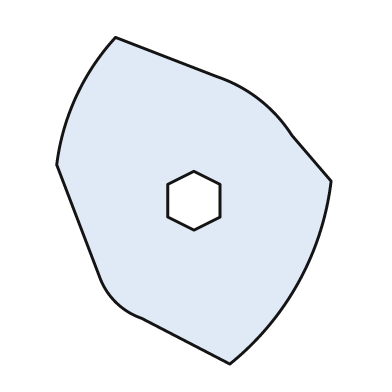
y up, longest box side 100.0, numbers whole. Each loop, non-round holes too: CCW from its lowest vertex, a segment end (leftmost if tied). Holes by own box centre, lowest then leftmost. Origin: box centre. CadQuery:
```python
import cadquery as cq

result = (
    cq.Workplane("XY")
    .moveTo(11.0, -50.0)
    .threePointArc((32.0, -25.0), (42.0, 6.0))
    .lineTo(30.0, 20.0)
    .threePointArc((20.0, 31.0), (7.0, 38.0))
    .lineTo(-24.0, 50.0)
    .threePointArc((-36.0, 32.0), (-42.0, 11.0))
    .lineTo(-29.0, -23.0)
    .threePointArc((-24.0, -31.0), (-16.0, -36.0))
    .close()
    .moveTo(0.0, -9.0)
    .lineTo(8.0, -5.0)
    .lineTo(8.0, 5.0)
    .lineTo(0.0, 9.0)
    .lineTo(-8.0, 5.0)
    .lineTo(-8.0, -5.0)
    .close()
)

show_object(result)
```